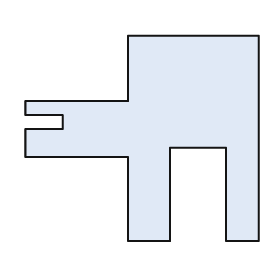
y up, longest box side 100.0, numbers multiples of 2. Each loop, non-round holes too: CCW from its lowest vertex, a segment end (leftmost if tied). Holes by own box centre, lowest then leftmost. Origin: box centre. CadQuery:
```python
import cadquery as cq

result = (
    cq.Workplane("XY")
    .moveTo(-6.0, -44.0)
    .lineTo(12.0, -44.0)
    .lineTo(12.0, -4.0)
    .lineTo(36.0, -4.0)
    .lineTo(36.0, -44.0)
    .lineTo(50.0, -44.0)
    .lineTo(50.0, 44.0)
    .lineTo(-6.0, 44.0)
    .lineTo(-6.0, 16.0)
    .lineTo(-50.0, 16.0)
    .lineTo(-50.0, 10.0)
    .lineTo(-34.0, 10.0)
    .lineTo(-34.0, 4.0)
    .lineTo(-50.0, 4.0)
    .lineTo(-50.0, -8.0)
    .lineTo(-6.0, -8.0)
    .close()
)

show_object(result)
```